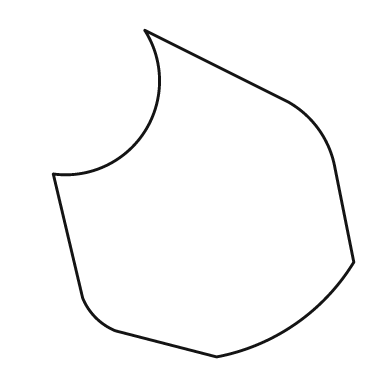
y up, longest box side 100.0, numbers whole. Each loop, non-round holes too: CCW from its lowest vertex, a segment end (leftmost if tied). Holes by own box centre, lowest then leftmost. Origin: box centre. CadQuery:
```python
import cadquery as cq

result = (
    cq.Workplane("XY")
    .moveTo(4.0, -50.0)
    .threePointArc((28.0, -40.0), (46.0, -21.0))
    .lineTo(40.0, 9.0)
    .threePointArc((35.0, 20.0), (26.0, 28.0))
    .lineTo(-18.0, 50.0)
    .threePointArc((-18.0, 19.0), (-46.0, 6.0))
    .lineTo(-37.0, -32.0)
    .threePointArc((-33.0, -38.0), (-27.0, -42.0))
    .close()
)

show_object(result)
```